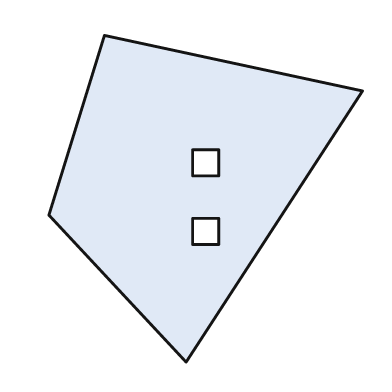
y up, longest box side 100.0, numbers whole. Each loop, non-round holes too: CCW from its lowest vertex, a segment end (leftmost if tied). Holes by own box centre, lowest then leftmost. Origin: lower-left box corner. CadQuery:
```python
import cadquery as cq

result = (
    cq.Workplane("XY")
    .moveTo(42.0, 0.0)
    .lineTo(96.0, 83.0)
    .lineTo(17.0, 100.0)
    .lineTo(0.0, 45.0)
    .close()
    .moveTo(44.0, 36.0)
    .lineTo(52.0, 36.0)
    .lineTo(52.0, 44.0)
    .lineTo(44.0, 44.0)
    .close()
    .moveTo(44.0, 57.0)
    .lineTo(52.0, 57.0)
    .lineTo(52.0, 65.0)
    .lineTo(44.0, 65.0)
    .close()
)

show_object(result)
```